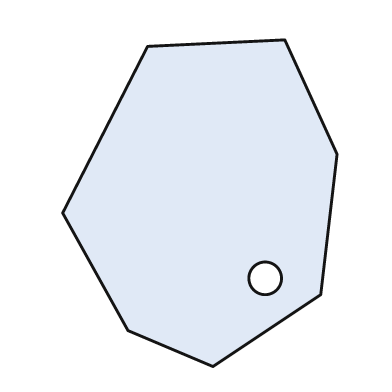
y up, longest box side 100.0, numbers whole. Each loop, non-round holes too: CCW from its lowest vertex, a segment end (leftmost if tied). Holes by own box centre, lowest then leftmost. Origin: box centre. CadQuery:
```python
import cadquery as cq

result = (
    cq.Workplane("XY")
    .moveTo(4.0, -50.0)
    .lineTo(37.0, -28.0)
    .lineTo(42.0, 15.0)
    .lineTo(26.0, 50.0)
    .lineTo(-16.0, 48.0)
    .lineTo(-42.0, -3.0)
    .lineTo(-22.0, -39.0)
    .close()
    .moveTo(20.0, -23.0)
    .circle(5.0)
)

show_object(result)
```